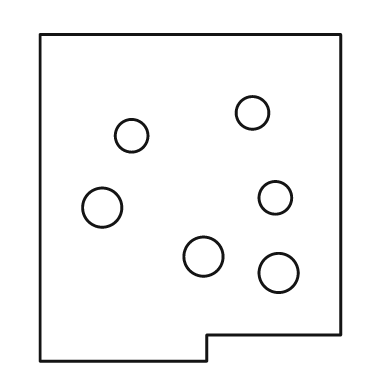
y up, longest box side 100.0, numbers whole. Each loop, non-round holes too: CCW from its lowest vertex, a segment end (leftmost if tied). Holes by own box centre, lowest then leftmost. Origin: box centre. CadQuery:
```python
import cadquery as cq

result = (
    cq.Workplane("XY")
    .moveTo(-46.0, -50.0)
    .lineTo(5.0, -50.0)
    .lineTo(5.0, -42.0)
    .lineTo(46.0, -42.0)
    .lineTo(46.0, 50.0)
    .lineTo(-46.0, 50.0)
    .close()
    .moveTo(27.0, -23.0)
    .circle(6.0)
    .moveTo(4.0, -18.0)
    .circle(6.0)
    .moveTo(-27.0, -3.0)
    .circle(6.0)
    .moveTo(26.0, 0.0)
    .circle(5.0)
    .moveTo(-18.0, 19.0)
    .circle(5.0)
    .moveTo(19.0, 26.0)
    .circle(5.0)
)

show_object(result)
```